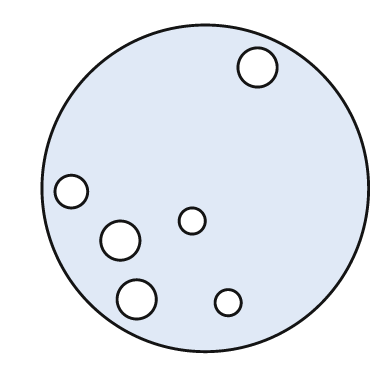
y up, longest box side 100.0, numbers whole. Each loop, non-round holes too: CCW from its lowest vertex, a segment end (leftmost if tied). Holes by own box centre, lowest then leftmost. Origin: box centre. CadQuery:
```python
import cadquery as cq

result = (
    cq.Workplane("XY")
    .moveTo(0.0, 0.0)
    .circle(50.0)
    .moveTo(7.0, -35.0)
    .circle(4.0)
    .moveTo(-21.0, -34.0)
    .circle(6.0)
    .moveTo(-26.0, -16.0)
    .circle(6.0)
    .moveTo(-4.0, -10.0)
    .circle(4.0)
    .moveTo(-41.0, -1.0)
    .circle(5.0)
    .moveTo(16.0, 37.0)
    .circle(6.0)
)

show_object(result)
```